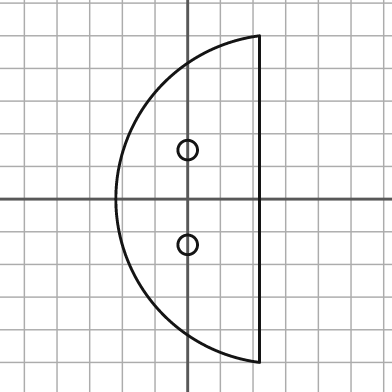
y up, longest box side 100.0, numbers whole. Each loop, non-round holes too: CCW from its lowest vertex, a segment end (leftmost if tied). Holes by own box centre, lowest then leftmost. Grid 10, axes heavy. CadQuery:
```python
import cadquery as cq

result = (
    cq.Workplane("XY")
    .moveTo(22.0, -50.0)
    .lineTo(22.0, 50.0)
    .threePointArc((-22.0, 0.0), (22.0, -50.0))
    .close()
    .moveTo(0.0, -14.0)
    .circle(3.0)
    .moveTo(0.0, 15.0)
    .circle(3.0)
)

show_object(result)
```